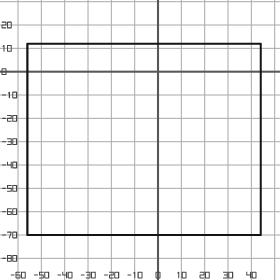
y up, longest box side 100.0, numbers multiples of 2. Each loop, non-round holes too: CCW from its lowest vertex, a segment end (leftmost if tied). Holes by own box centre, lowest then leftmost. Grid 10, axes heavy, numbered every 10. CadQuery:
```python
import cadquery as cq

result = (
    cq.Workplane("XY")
    .moveTo(-56.0, -70.0)
    .lineTo(44.0, -70.0)
    .lineTo(44.0, 12.0)
    .lineTo(-56.0, 12.0)
    .close()
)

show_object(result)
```